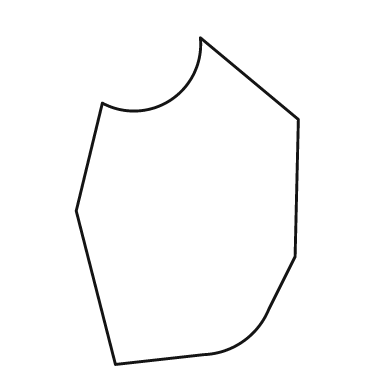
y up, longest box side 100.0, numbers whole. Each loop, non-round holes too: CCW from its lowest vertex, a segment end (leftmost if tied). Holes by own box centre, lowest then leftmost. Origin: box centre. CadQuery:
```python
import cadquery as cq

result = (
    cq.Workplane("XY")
    .moveTo(-22.0, -50.0)
    .lineTo(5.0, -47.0)
    .threePointArc((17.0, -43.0), (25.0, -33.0))
    .lineTo(33.0, -17.0)
    .lineTo(34.0, 25.0)
    .lineTo(4.0, 50.0)
    .threePointArc((-5.0, 31.0), (-26.0, 30.0))
    .lineTo(-34.0, -3.0)
    .close()
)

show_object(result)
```